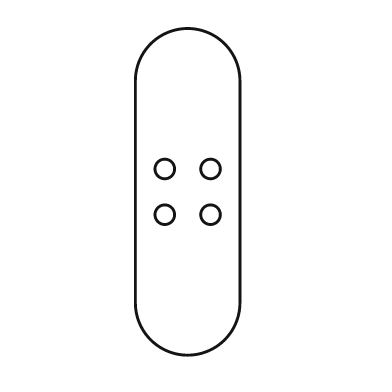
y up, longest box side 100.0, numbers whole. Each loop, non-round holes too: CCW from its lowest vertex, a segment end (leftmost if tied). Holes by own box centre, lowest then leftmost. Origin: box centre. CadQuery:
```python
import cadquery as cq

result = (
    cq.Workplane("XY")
    .moveTo(-16.0, -34.0)
    .threePointArc((0.0, -50.0), (16.0, -34.0))
    .lineTo(16.0, 34.0)
    .threePointArc((0.0, 50.0), (-16.0, 34.0))
    .close()
    .moveTo(-7.0, -7.0)
    .circle(3.0)
    .moveTo(7.0, -7.0)
    .circle(3.0)
    .moveTo(-7.0, 7.0)
    .circle(3.0)
    .moveTo(7.0, 7.0)
    .circle(3.0)
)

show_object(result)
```